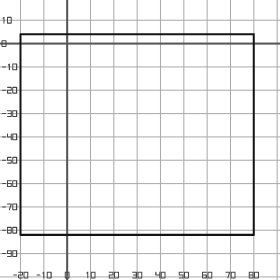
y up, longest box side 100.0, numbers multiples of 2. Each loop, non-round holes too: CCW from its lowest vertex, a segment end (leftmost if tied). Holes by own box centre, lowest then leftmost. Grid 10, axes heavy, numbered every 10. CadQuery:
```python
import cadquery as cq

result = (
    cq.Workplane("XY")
    .moveTo(-20.0, -82.0)
    .lineTo(80.0, -82.0)
    .lineTo(80.0, 4.0)
    .lineTo(-20.0, 4.0)
    .close()
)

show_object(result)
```